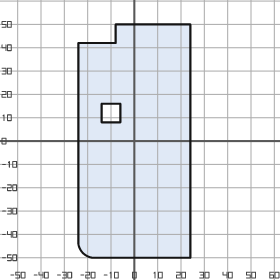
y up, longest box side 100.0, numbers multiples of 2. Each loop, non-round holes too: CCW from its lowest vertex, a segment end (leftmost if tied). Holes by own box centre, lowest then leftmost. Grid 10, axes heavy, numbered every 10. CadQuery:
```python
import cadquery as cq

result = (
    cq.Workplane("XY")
    .moveTo(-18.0, -50.0)
    .lineTo(24.0, -50.0)
    .lineTo(24.0, 50.0)
    .lineTo(-8.0, 50.0)
    .lineTo(-8.0, 42.0)
    .lineTo(-24.0, 42.0)
    .lineTo(-24.0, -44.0)
    .threePointArc((-22.0, -48.0), (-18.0, -50.0))
    .close()
    .moveTo(-14.0, 8.0)
    .lineTo(-6.0, 8.0)
    .lineTo(-6.0, 16.0)
    .lineTo(-14.0, 16.0)
    .close()
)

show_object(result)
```